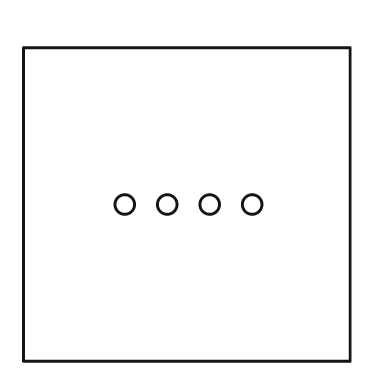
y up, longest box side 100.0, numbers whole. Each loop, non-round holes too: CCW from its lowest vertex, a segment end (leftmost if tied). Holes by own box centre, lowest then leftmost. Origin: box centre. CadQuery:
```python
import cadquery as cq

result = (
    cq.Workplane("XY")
    .moveTo(-50.0, -48.0)
    .lineTo(50.0, -48.0)
    .lineTo(50.0, 48.0)
    .lineTo(-50.0, 48.0)
    .close()
    .moveTo(-19.0, 0.0)
    .circle(3.0)
    .moveTo(-6.0, 0.0)
    .circle(3.0)
    .moveTo(7.0, 0.0)
    .circle(3.0)
    .moveTo(20.0, 0.0)
    .circle(3.0)
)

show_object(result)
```